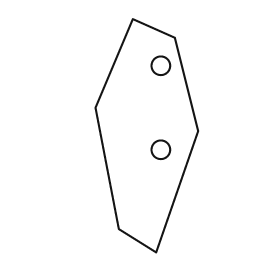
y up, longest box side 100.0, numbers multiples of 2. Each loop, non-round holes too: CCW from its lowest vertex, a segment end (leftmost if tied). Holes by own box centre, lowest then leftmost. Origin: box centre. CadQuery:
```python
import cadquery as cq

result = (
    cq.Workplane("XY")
    .moveTo(4.0, -50.0)
    .lineTo(22.0, 2.0)
    .lineTo(12.0, 42.0)
    .lineTo(-6.0, 50.0)
    .lineTo(-22.0, 12.0)
    .lineTo(-12.0, -40.0)
    .close()
    .moveTo(6.0, -6.0)
    .circle(4.0)
    .moveTo(6.0, 30.0)
    .circle(4.0)
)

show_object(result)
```